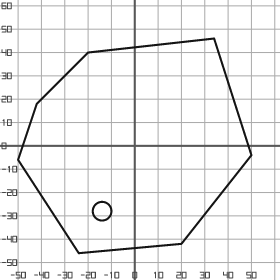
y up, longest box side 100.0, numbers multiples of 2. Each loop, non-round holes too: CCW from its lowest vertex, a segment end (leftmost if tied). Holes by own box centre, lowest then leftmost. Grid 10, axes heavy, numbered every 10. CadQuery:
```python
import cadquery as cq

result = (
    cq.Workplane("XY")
    .moveTo(-24.0, -46.0)
    .lineTo(20.0, -42.0)
    .lineTo(50.0, -4.0)
    .lineTo(34.0, 46.0)
    .lineTo(-20.0, 40.0)
    .lineTo(-42.0, 18.0)
    .lineTo(-50.0, -6.0)
    .close()
    .moveTo(-14.0, -28.0)
    .circle(4.0)
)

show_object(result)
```